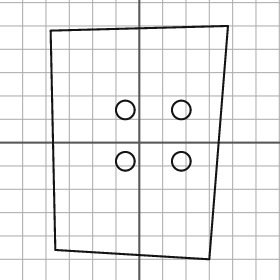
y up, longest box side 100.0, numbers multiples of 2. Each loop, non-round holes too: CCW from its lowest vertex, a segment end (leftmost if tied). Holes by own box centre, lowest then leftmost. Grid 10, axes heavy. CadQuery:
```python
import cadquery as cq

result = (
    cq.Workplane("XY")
    .moveTo(30.0, -50.0)
    .lineTo(38.0, 50.0)
    .lineTo(-38.0, 48.0)
    .lineTo(-36.0, -46.0)
    .close()
    .moveTo(-6.0, -8.0)
    .circle(4.0)
    .moveTo(18.0, -8.0)
    .circle(4.0)
    .moveTo(-6.0, 14.0)
    .circle(4.0)
    .moveTo(18.0, 14.0)
    .circle(4.0)
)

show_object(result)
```